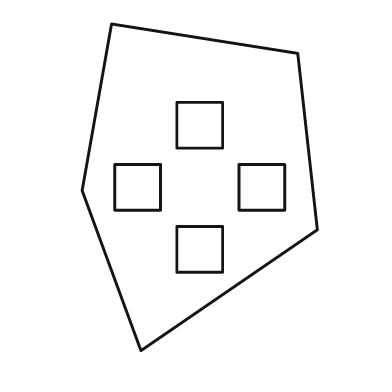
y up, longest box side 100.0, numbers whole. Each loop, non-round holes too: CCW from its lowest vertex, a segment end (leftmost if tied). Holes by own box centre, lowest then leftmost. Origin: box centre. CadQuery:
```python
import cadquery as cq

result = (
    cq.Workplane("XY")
    .moveTo(-18.0, -50.0)
    .lineTo(36.0, -13.0)
    .lineTo(30.0, 41.0)
    .lineTo(-27.0, 50.0)
    .lineTo(-36.0, -1.0)
    .close()
    .moveTo(-7.0, -26.0)
    .lineTo(7.0, -26.0)
    .lineTo(7.0, -12.0)
    .lineTo(-7.0, -12.0)
    .close()
    .moveTo(-26.0, -7.0)
    .lineTo(-12.0, -7.0)
    .lineTo(-12.0, 7.0)
    .lineTo(-26.0, 7.0)
    .close()
    .moveTo(12.0, -7.0)
    .lineTo(26.0, -7.0)
    .lineTo(26.0, 7.0)
    .lineTo(12.0, 7.0)
    .close()
    .moveTo(-7.0, 12.0)
    .lineTo(7.0, 12.0)
    .lineTo(7.0, 26.0)
    .lineTo(-7.0, 26.0)
    .close()
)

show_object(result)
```